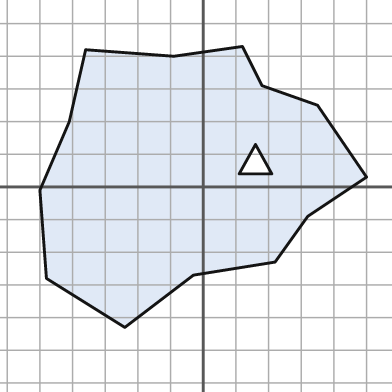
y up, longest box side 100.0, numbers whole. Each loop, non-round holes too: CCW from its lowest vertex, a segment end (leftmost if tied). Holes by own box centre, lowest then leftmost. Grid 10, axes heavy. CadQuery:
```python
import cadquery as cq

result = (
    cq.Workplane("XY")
    .moveTo(-24.0, -43.0)
    .lineTo(-3.0, -27.0)
    .lineTo(22.0, -23.0)
    .lineTo(32.0, -9.0)
    .lineTo(50.0, 3.0)
    .lineTo(35.0, 25.0)
    .lineTo(18.0, 31.0)
    .lineTo(12.0, 43.0)
    .lineTo(-9.0, 40.0)
    .lineTo(-36.0, 42.0)
    .lineTo(-41.0, 20.0)
    .lineTo(-50.0, -1.0)
    .lineTo(-48.0, -28.0)
    .close()
    .moveTo(11.0, 4.0)
    .lineTo(21.0, 4.0)
    .lineTo(16.0, 13.0)
    .close()
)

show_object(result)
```